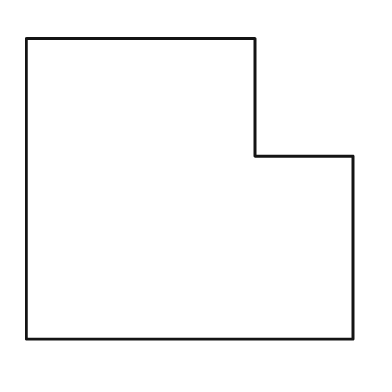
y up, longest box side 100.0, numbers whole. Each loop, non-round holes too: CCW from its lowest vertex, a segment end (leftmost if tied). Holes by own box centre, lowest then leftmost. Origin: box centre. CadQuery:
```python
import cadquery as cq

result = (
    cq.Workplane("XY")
    .moveTo(-50.0, -46.0)
    .lineTo(50.0, -46.0)
    .lineTo(50.0, 10.0)
    .lineTo(20.0, 10.0)
    .lineTo(20.0, 46.0)
    .lineTo(-50.0, 46.0)
    .close()
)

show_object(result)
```